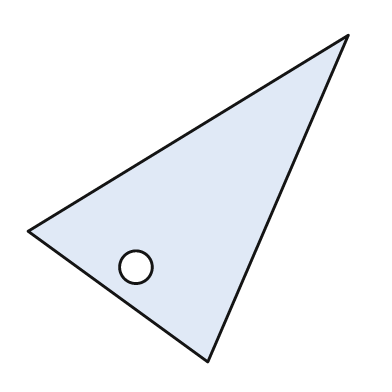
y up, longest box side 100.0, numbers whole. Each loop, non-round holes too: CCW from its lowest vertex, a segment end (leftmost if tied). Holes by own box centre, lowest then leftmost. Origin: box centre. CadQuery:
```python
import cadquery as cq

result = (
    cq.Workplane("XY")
    .moveTo(6.0, -50.0)
    .lineTo(49.0, 50.0)
    .lineTo(-49.0, -10.0)
    .close()
    .moveTo(-16.0, -21.0)
    .circle(5.0)
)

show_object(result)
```